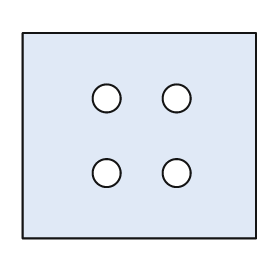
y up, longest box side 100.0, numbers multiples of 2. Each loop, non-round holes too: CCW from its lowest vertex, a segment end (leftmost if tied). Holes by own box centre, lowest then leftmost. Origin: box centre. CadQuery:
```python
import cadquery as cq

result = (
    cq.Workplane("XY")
    .moveTo(-50.0, -44.0)
    .lineTo(50.0, -44.0)
    .lineTo(50.0, 44.0)
    .lineTo(-50.0, 44.0)
    .close()
    .moveTo(-14.0, -16.0)
    .circle(6.0)
    .moveTo(16.0, -16.0)
    .circle(6.0)
    .moveTo(-14.0, 16.0)
    .circle(6.0)
    .moveTo(16.0, 16.0)
    .circle(6.0)
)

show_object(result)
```